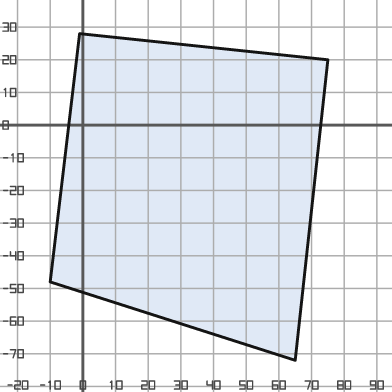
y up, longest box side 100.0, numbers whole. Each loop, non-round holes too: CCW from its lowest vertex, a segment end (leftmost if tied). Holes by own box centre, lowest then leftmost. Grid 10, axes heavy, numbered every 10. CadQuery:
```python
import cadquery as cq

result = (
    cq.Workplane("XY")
    .moveTo(65.0, -72.0)
    .lineTo(75.0, 20.0)
    .lineTo(-1.0, 28.0)
    .lineTo(-10.0, -48.0)
    .close()
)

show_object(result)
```